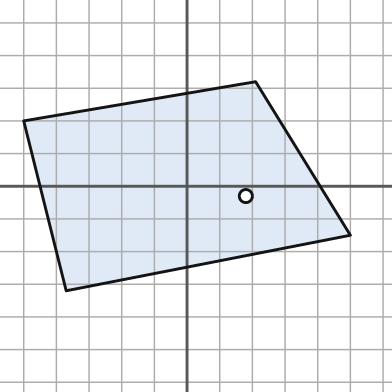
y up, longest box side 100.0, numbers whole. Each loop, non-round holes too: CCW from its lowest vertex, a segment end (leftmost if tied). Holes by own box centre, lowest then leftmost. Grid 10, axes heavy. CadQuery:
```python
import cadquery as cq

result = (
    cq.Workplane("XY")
    .moveTo(-37.0, -32.0)
    .lineTo(50.0, -15.0)
    .lineTo(21.0, 32.0)
    .lineTo(-50.0, 20.0)
    .close()
    .moveTo(18.0, -3.0)
    .circle(2.0)
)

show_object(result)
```